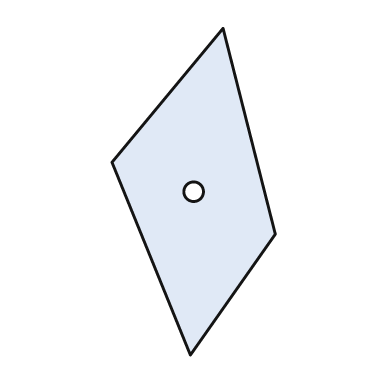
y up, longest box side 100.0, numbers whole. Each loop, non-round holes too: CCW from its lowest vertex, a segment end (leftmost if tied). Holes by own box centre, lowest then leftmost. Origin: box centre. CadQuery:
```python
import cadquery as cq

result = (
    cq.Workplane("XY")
    .moveTo(-1.0, -50.0)
    .lineTo(25.0, -13.0)
    .lineTo(9.0, 50.0)
    .lineTo(-25.0, 9.0)
    .close()
    .moveTo(0.0, 0.0)
    .circle(3.0)
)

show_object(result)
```